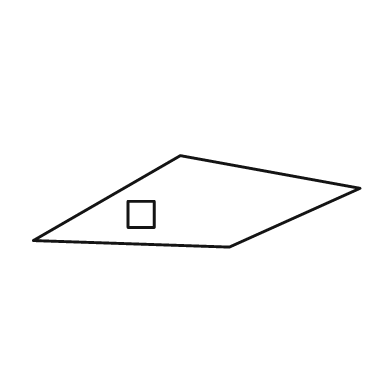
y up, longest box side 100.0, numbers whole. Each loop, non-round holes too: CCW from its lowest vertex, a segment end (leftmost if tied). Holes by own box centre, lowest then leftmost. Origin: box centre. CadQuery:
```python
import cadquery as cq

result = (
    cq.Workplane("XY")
    .moveTo(10.0, -14.0)
    .lineTo(50.0, 4.0)
    .lineTo(-5.0, 14.0)
    .lineTo(-50.0, -12.0)
    .close()
    .moveTo(-21.0, -8.0)
    .lineTo(-13.0, -8.0)
    .lineTo(-13.0, 0.0)
    .lineTo(-21.0, 0.0)
    .close()
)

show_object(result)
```